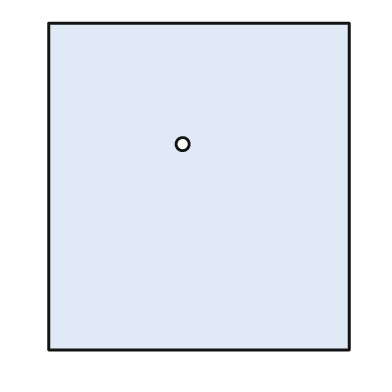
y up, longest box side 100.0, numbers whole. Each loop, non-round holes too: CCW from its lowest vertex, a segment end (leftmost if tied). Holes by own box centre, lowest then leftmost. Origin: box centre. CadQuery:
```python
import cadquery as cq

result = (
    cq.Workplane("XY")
    .moveTo(-46.0, -50.0)
    .lineTo(46.0, -50.0)
    .lineTo(46.0, 50.0)
    .lineTo(-46.0, 50.0)
    .close()
    .moveTo(-5.0, 13.0)
    .circle(2.0)
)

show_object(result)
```